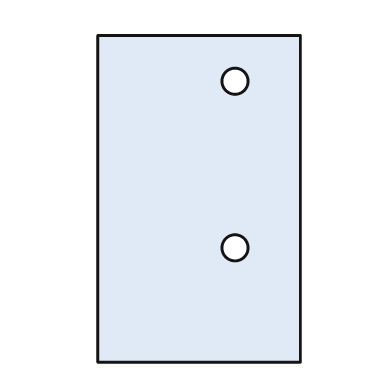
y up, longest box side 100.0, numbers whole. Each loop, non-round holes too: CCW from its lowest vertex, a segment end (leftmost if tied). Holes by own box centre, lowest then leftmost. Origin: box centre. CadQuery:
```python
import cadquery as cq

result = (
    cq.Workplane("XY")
    .moveTo(-31.0, -50.0)
    .lineTo(31.0, -50.0)
    .lineTo(31.0, 50.0)
    .lineTo(-31.0, 50.0)
    .close()
    .moveTo(11.0, -15.0)
    .circle(4.0)
    .moveTo(11.0, 36.0)
    .circle(4.0)
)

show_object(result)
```